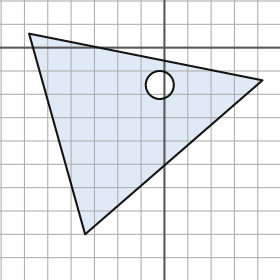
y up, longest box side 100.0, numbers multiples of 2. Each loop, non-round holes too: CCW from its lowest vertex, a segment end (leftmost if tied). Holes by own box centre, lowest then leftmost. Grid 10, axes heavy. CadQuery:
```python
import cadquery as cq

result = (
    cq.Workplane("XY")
    .moveTo(-34.0, -80.0)
    .lineTo(42.0, -14.0)
    .lineTo(-58.0, 6.0)
    .close()
    .moveTo(-2.0, -16.0)
    .circle(6.0)
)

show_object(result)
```